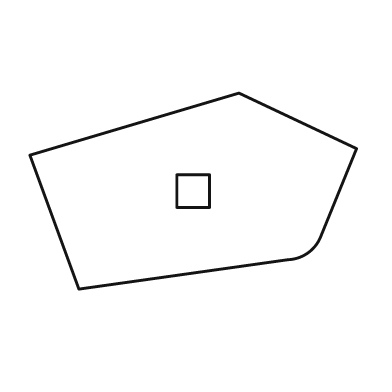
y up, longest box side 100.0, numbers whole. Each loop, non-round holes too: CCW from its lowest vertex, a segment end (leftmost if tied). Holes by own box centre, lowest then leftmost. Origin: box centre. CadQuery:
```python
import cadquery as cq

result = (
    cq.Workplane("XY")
    .moveTo(-35.0, -30.0)
    .lineTo(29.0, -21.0)
    .threePointArc((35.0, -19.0), (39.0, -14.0))
    .lineTo(50.0, 13.0)
    .lineTo(14.0, 30.0)
    .lineTo(-50.0, 11.0)
    .close()
    .moveTo(-5.0, -5.0)
    .lineTo(5.0, -5.0)
    .lineTo(5.0, 5.0)
    .lineTo(-5.0, 5.0)
    .close()
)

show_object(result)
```